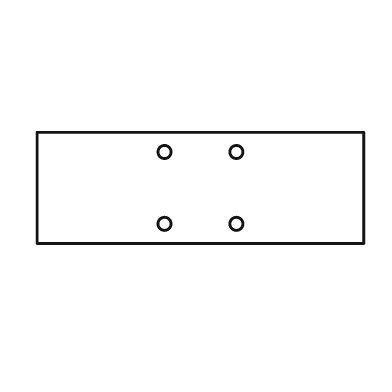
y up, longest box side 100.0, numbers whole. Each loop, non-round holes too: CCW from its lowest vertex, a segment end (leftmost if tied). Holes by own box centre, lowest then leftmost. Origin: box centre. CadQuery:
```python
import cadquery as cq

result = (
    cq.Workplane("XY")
    .moveTo(-50.0, -17.0)
    .lineTo(50.0, -17.0)
    .lineTo(50.0, 17.0)
    .lineTo(-50.0, 17.0)
    .close()
    .moveTo(-11.0, -11.0)
    .circle(2.0)
    .moveTo(11.0, -11.0)
    .circle(2.0)
    .moveTo(-11.0, 11.0)
    .circle(2.0)
    .moveTo(11.0, 11.0)
    .circle(2.0)
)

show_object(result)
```